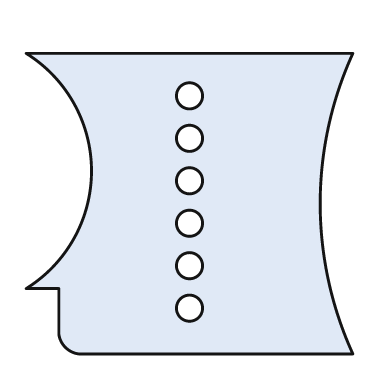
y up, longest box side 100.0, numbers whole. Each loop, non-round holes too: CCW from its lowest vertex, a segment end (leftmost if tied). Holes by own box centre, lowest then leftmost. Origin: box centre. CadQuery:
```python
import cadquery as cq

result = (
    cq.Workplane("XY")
    .moveTo(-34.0, -46.0)
    .lineTo(50.0, -46.0)
    .threePointArc((40.0, 0.0), (50.0, 46.0))
    .lineTo(-50.0, 46.0)
    .threePointArc((-30.0, 10.0), (-50.0, -26.0))
    .lineTo(-40.0, -26.0)
    .lineTo(-40.0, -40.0)
    .threePointArc((-38.0, -44.0), (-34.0, -46.0))
    .close()
    .moveTo(0.0, -32.0)
    .circle(4.0)
    .moveTo(0.0, -19.0)
    .circle(4.0)
    .moveTo(0.0, -6.0)
    .circle(4.0)
    .moveTo(0.0, 7.0)
    .circle(4.0)
    .moveTo(0.0, 20.0)
    .circle(4.0)
    .moveTo(0.0, 33.0)
    .circle(4.0)
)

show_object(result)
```